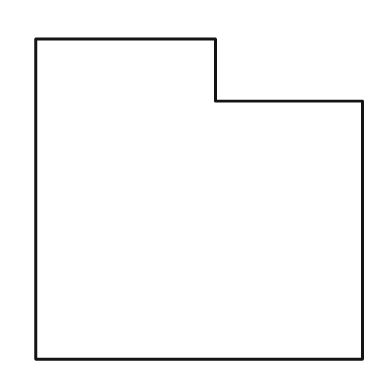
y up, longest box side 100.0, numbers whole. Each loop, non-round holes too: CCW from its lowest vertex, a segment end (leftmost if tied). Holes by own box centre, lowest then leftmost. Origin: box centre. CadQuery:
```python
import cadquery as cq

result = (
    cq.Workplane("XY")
    .moveTo(-50.0, -49.0)
    .lineTo(50.0, -49.0)
    .lineTo(50.0, 30.0)
    .lineTo(5.0, 30.0)
    .lineTo(5.0, 49.0)
    .lineTo(-50.0, 49.0)
    .close()
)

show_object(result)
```